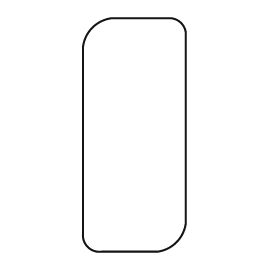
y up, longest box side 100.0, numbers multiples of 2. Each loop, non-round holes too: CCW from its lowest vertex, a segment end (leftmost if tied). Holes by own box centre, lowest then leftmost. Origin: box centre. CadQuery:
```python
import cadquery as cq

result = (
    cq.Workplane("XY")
    .moveTo(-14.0, -50.0)
    .lineTo(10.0, -50.0)
    .threePointArc((18.0, -46.0), (22.0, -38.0))
    .lineTo(22.0, 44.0)
    .threePointArc((20.0, 48.0), (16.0, 50.0))
    .lineTo(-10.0, 50.0)
    .threePointArc((-18.0, 46.0), (-22.0, 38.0))
    .lineTo(-22.0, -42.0)
    .threePointArc((-20.0, -48.0), (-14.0, -50.0))
    .close()
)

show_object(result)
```